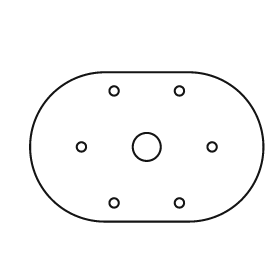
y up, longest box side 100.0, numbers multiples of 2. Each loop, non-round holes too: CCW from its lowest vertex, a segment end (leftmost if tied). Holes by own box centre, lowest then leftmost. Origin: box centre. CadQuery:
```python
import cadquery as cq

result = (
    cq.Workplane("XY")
    .moveTo(-18.0, -32.0)
    .lineTo(18.0, -32.0)
    .threePointArc((50.0, 0.0), (18.0, 32.0))
    .lineTo(-18.0, 32.0)
    .threePointArc((-50.0, 0.0), (-18.0, -32.0))
    .close()
    .moveTo(-14.0, -24.0)
    .circle(2.0)
    .moveTo(14.0, -24.0)
    .circle(2.0)
    .moveTo(-28.0, 0.0)
    .circle(2.0)
    .moveTo(0.0, 0.0)
    .circle(6.0)
    .moveTo(28.0, 0.0)
    .circle(2.0)
    .moveTo(-14.0, 24.0)
    .circle(2.0)
    .moveTo(14.0, 24.0)
    .circle(2.0)
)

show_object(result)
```